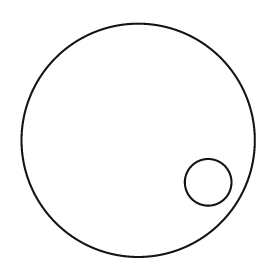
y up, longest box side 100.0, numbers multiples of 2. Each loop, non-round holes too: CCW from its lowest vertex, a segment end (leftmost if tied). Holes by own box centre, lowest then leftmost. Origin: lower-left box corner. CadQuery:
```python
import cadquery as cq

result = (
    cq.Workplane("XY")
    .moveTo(50.0, 50.0)
    .circle(50.0)
    .moveTo(80.0, 32.0)
    .circle(10.0)
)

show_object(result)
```